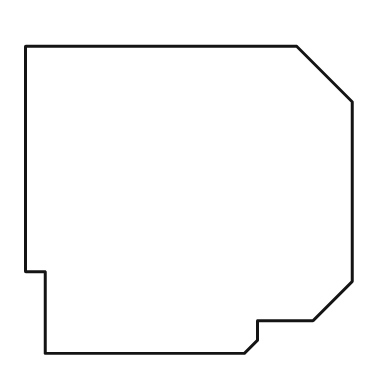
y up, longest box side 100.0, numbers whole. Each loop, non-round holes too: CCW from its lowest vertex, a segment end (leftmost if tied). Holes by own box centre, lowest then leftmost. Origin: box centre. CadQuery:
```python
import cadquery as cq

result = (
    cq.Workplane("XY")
    .moveTo(-44.0, -47.0)
    .lineTo(17.0, -47.0)
    .lineTo(21.0, -43.0)
    .lineTo(21.0, -37.0)
    .lineTo(38.0, -37.0)
    .lineTo(50.0, -25.0)
    .lineTo(50.0, 30.0)
    .lineTo(33.0, 47.0)
    .lineTo(-50.0, 47.0)
    .lineTo(-50.0, -22.0)
    .lineTo(-44.0, -22.0)
    .close()
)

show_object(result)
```